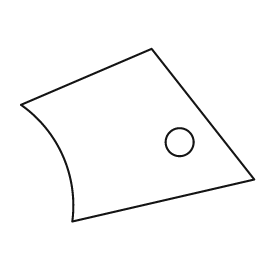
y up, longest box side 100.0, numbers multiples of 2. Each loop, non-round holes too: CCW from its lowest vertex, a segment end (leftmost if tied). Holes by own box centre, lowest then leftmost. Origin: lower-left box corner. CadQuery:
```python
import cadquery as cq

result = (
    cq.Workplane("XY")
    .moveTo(22.0, 0.0)
    .lineTo(100.0, 18.0)
    .lineTo(56.0, 74.0)
    .lineTo(0.0, 50.0)
    .threePointArc((18.0, 28.0), (22.0, 0.0))
    .close()
    .moveTo(68.0, 34.0)
    .circle(6.0)
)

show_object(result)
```